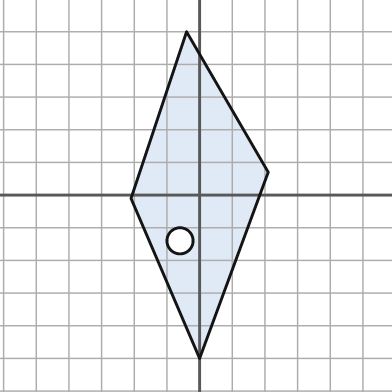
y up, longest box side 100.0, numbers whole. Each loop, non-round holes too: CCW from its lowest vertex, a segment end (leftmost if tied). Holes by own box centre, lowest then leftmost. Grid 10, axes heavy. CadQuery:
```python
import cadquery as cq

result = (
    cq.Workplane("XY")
    .moveTo(0.0, -50.0)
    .lineTo(21.0, 7.0)
    .lineTo(-4.0, 50.0)
    .lineTo(-21.0, -1.0)
    .close()
    .moveTo(-6.0, -14.0)
    .circle(4.0)
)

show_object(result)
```